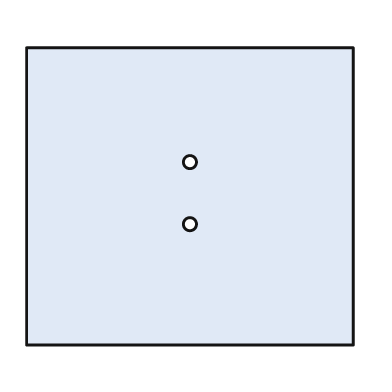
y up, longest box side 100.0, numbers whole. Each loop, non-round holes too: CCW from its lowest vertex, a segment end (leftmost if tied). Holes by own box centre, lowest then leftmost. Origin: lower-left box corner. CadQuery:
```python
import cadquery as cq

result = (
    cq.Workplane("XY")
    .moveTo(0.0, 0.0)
    .lineTo(100.0, 0.0)
    .lineTo(100.0, 91.0)
    .lineTo(0.0, 91.0)
    .close()
    .moveTo(50.0, 37.0)
    .circle(2.0)
    .moveTo(50.0, 56.0)
    .circle(2.0)
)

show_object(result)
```